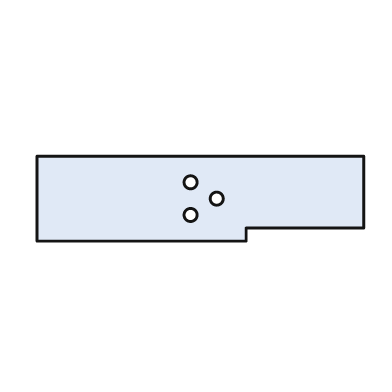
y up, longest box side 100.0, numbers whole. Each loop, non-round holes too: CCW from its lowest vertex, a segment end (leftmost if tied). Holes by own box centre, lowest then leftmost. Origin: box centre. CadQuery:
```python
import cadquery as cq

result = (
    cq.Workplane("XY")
    .moveTo(-50.0, -13.0)
    .lineTo(14.0, -13.0)
    .lineTo(14.0, -9.0)
    .lineTo(50.0, -9.0)
    .lineTo(50.0, 13.0)
    .lineTo(-50.0, 13.0)
    .close()
    .moveTo(-3.0, -5.0)
    .circle(2.0)
    .moveTo(5.0, 0.0)
    .circle(2.0)
    .moveTo(-3.0, 5.0)
    .circle(2.0)
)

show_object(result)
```